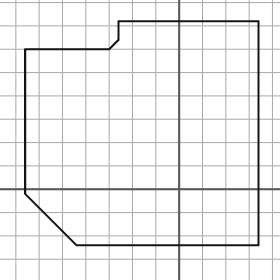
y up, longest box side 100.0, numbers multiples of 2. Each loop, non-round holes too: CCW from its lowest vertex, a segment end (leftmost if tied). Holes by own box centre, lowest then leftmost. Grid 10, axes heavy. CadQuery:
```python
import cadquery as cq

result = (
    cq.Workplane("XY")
    .moveTo(-44.0, -24.0)
    .lineTo(34.0, -24.0)
    .lineTo(34.0, 72.0)
    .lineTo(-26.0, 72.0)
    .lineTo(-26.0, 64.0)
    .lineTo(-30.0, 60.0)
    .lineTo(-66.0, 60.0)
    .lineTo(-66.0, -2.0)
    .close()
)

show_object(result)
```